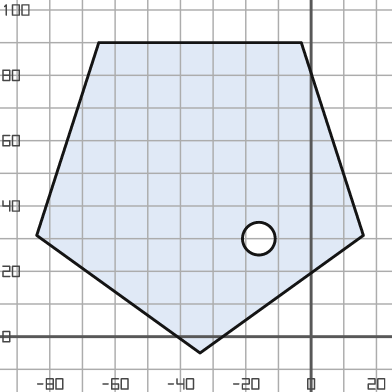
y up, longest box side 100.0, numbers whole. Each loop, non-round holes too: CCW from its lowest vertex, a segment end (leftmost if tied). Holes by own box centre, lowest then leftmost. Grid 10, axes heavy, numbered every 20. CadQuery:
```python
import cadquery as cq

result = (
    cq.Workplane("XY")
    .moveTo(-34.0, -5.0)
    .lineTo(16.0, 31.0)
    .lineTo(-3.0, 90.0)
    .lineTo(-65.0, 90.0)
    .lineTo(-84.0, 31.0)
    .close()
    .moveTo(-16.0, 30.0)
    .circle(5.0)
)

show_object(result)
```